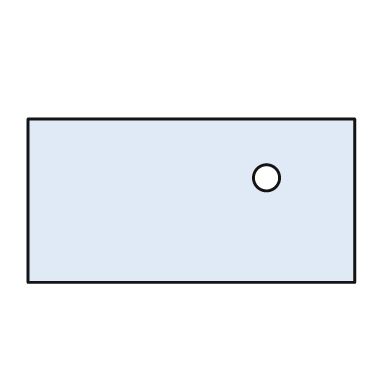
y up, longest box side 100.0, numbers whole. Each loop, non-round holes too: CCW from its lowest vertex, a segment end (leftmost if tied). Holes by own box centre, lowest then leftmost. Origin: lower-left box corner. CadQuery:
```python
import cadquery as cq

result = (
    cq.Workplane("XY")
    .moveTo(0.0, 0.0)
    .lineTo(100.0, 0.0)
    .lineTo(100.0, 50.0)
    .lineTo(0.0, 50.0)
    .close()
    .moveTo(73.0, 32.0)
    .circle(4.0)
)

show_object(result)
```